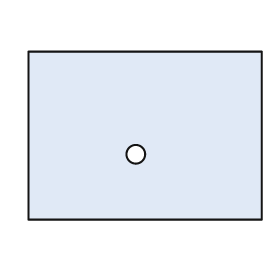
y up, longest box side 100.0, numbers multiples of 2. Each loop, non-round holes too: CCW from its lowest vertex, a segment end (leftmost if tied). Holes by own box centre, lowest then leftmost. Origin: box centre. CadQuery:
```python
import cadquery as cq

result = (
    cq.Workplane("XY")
    .moveTo(-50.0, -36.0)
    .lineTo(50.0, -36.0)
    .lineTo(50.0, 36.0)
    .lineTo(-50.0, 36.0)
    .close()
    .moveTo(-4.0, -8.0)
    .circle(4.0)
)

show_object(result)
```